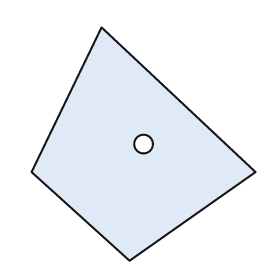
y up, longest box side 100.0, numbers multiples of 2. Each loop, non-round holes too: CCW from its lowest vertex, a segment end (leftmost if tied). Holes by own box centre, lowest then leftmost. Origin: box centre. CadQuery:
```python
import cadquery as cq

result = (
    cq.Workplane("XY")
    .moveTo(-6.0, -50.0)
    .lineTo(48.0, -12.0)
    .lineTo(-18.0, 50.0)
    .lineTo(-48.0, -12.0)
    .close()
    .moveTo(0.0, 0.0)
    .circle(4.0)
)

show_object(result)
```